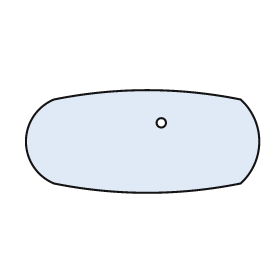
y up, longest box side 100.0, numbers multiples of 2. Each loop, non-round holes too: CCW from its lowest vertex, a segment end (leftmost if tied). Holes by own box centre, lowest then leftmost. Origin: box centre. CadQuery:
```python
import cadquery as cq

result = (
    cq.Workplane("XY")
    .moveTo(-38.0, -18.0)
    .threePointArc((2.0, -22.0), (42.0, -18.0))
    .threePointArc((50.0, 0.0), (42.0, 18.0))
    .threePointArc((2.0, 22.0), (-38.0, 18.0))
    .threePointArc((-50.0, 0.0), (-38.0, -18.0))
    .close()
    .moveTo(8.0, 8.0)
    .circle(2.0)
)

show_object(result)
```